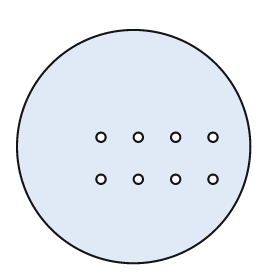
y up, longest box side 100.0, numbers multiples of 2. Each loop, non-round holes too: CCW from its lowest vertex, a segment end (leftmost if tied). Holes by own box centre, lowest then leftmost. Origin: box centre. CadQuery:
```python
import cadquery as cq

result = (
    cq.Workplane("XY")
    .moveTo(0.0, 0.0)
    .circle(50.0)
    .moveTo(-14.0, -14.0)
    .circle(2.0)
    .moveTo(2.0, -14.0)
    .circle(2.0)
    .moveTo(18.0, -14.0)
    .circle(2.0)
    .moveTo(34.0, -14.0)
    .circle(2.0)
    .moveTo(-14.0, 4.0)
    .circle(2.0)
    .moveTo(2.0, 4.0)
    .circle(2.0)
    .moveTo(18.0, 4.0)
    .circle(2.0)
    .moveTo(34.0, 4.0)
    .circle(2.0)
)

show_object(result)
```